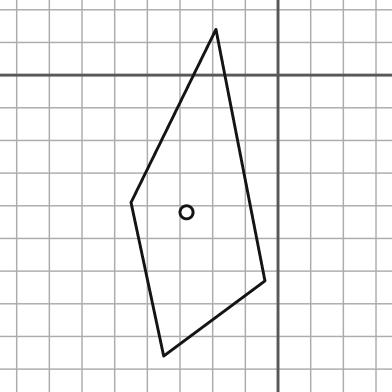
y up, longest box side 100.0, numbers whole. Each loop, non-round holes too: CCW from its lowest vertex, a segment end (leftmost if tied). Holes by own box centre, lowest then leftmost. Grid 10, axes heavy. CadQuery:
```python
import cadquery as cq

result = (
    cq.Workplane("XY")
    .moveTo(-35.0, -86.0)
    .lineTo(-4.0, -63.0)
    .lineTo(-19.0, 14.0)
    .lineTo(-45.0, -39.0)
    .close()
    .moveTo(-28.0, -42.0)
    .circle(2.0)
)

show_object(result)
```